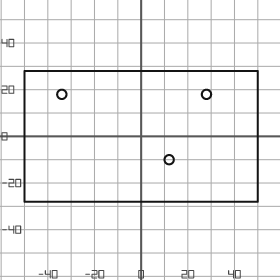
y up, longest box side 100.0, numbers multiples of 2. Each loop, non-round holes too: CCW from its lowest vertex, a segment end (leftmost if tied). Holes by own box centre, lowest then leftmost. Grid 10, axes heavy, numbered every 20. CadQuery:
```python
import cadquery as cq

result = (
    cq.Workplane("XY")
    .moveTo(-50.0, -28.0)
    .lineTo(50.0, -28.0)
    .lineTo(50.0, 28.0)
    .lineTo(-50.0, 28.0)
    .close()
    .moveTo(12.0, -10.0)
    .circle(2.0)
    .moveTo(-34.0, 18.0)
    .circle(2.0)
    .moveTo(28.0, 18.0)
    .circle(2.0)
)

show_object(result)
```